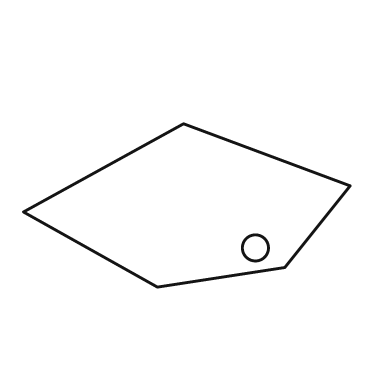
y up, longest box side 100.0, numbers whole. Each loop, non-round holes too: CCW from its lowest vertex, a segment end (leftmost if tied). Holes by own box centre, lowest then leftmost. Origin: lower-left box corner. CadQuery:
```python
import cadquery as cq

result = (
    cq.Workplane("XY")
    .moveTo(41.0, 0.0)
    .lineTo(80.0, 6.0)
    .lineTo(100.0, 31.0)
    .lineTo(49.0, 50.0)
    .lineTo(0.0, 23.0)
    .close()
    .moveTo(71.0, 12.0)
    .circle(4.0)
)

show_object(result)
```